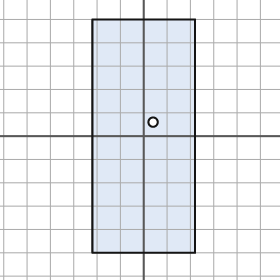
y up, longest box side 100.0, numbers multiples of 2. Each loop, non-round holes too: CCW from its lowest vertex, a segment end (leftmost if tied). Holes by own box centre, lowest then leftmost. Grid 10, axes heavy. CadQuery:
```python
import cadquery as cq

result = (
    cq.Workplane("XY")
    .moveTo(-22.0, -50.0)
    .lineTo(22.0, -50.0)
    .lineTo(22.0, 50.0)
    .lineTo(-22.0, 50.0)
    .close()
    .moveTo(4.0, 6.0)
    .circle(2.0)
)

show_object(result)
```